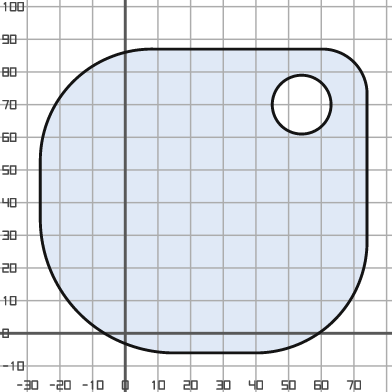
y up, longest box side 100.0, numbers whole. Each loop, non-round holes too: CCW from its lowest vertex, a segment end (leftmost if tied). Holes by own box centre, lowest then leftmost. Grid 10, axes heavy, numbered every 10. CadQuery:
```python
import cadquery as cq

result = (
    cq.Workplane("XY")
    .moveTo(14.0, -6.0)
    .lineTo(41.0, -6.0)
    .threePointArc((64.0, 4.0), (74.0, 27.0))
    .lineTo(74.0, 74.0)
    .threePointArc((70.0, 83.0), (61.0, 87.0))
    .lineTo(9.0, 87.0)
    .threePointArc((-16.0, 77.0), (-26.0, 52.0))
    .lineTo(-26.0, 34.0)
    .threePointArc((-14.0, 6.0), (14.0, -6.0))
    .close()
    .moveTo(54.0, 70.0)
    .circle(9.0)
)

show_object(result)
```